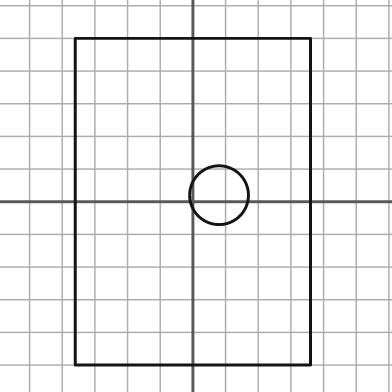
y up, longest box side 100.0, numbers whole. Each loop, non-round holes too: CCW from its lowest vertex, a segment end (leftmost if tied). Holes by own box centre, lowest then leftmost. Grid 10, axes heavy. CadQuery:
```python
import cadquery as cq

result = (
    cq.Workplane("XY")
    .moveTo(-36.0, -50.0)
    .lineTo(36.0, -50.0)
    .lineTo(36.0, 50.0)
    .lineTo(-36.0, 50.0)
    .close()
    .moveTo(8.0, 2.0)
    .circle(9.0)
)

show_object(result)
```